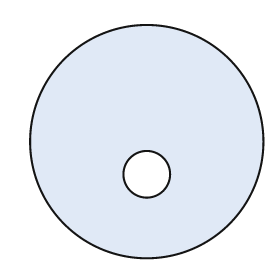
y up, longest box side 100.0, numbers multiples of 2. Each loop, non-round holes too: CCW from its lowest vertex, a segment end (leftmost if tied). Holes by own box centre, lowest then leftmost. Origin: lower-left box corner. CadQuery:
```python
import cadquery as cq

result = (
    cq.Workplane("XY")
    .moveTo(50.0, 50.0)
    .circle(50.0)
    .moveTo(50.0, 36.0)
    .circle(10.0)
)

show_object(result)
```